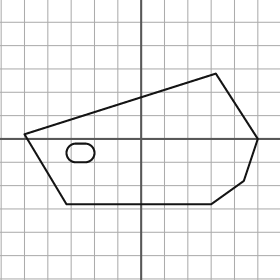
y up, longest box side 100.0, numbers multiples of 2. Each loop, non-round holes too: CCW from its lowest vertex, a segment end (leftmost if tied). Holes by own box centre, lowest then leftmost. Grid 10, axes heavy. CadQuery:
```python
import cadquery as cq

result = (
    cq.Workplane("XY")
    .moveTo(-32.0, -28.0)
    .lineTo(30.0, -28.0)
    .lineTo(44.0, -18.0)
    .lineTo(50.0, 0.0)
    .lineTo(32.0, 28.0)
    .lineTo(-50.0, 2.0)
    .close()
    .moveTo(-28.0, -10.0)
    .lineTo(-24.0, -10.0)
    .threePointArc((-20.0, -6.0), (-24.0, -2.0))
    .lineTo(-28.0, -2.0)
    .threePointArc((-32.0, -6.0), (-28.0, -10.0))
    .close()
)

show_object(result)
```